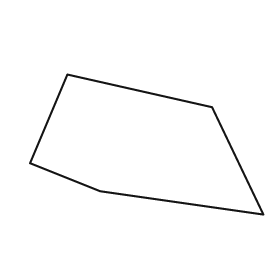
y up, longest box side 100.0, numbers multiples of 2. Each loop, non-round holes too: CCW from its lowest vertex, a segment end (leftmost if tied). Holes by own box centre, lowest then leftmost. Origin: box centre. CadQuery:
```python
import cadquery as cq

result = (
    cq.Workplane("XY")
    .moveTo(50.0, -30.0)
    .lineTo(28.0, 16.0)
    .lineTo(-34.0, 30.0)
    .lineTo(-50.0, -8.0)
    .lineTo(-20.0, -20.0)
    .close()
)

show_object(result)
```